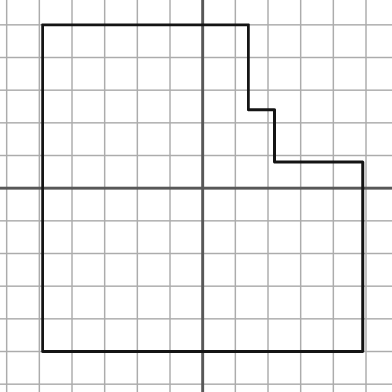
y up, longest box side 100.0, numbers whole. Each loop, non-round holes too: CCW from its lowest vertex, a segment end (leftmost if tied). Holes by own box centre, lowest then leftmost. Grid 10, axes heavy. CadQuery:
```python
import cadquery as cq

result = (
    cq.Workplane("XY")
    .moveTo(-49.0, -50.0)
    .lineTo(49.0, -50.0)
    .lineTo(49.0, 8.0)
    .lineTo(22.0, 8.0)
    .lineTo(22.0, 24.0)
    .lineTo(14.0, 24.0)
    .lineTo(14.0, 50.0)
    .lineTo(-49.0, 50.0)
    .close()
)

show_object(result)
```